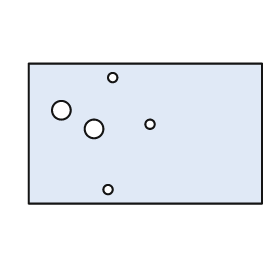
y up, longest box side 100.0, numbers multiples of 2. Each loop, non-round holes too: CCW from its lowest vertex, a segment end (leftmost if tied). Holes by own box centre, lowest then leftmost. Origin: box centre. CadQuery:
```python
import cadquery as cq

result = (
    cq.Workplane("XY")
    .moveTo(-50.0, -30.0)
    .lineTo(50.0, -30.0)
    .lineTo(50.0, 30.0)
    .lineTo(-50.0, 30.0)
    .close()
    .moveTo(-16.0, -24.0)
    .circle(2.0)
    .moveTo(-22.0, 2.0)
    .circle(4.0)
    .moveTo(2.0, 4.0)
    .circle(2.0)
    .moveTo(-36.0, 10.0)
    .circle(4.0)
    .moveTo(-14.0, 24.0)
    .circle(2.0)
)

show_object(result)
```